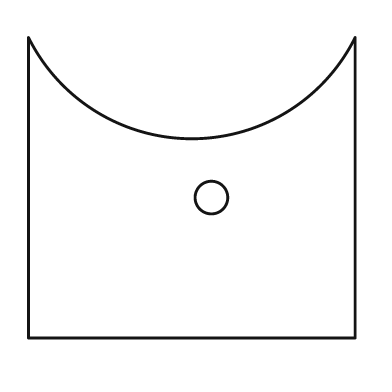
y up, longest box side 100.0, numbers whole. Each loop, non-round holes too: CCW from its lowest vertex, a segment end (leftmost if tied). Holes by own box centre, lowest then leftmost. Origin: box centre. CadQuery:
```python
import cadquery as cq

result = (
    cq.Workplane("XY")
    .moveTo(-50.0, -46.0)
    .lineTo(50.0, -46.0)
    .lineTo(50.0, 46.0)
    .threePointArc((0.0, 15.0), (-50.0, 46.0))
    .close()
    .moveTo(6.0, -3.0)
    .circle(5.0)
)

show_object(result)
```